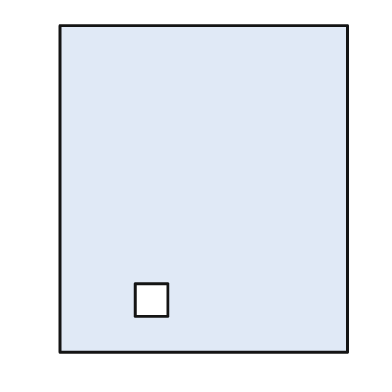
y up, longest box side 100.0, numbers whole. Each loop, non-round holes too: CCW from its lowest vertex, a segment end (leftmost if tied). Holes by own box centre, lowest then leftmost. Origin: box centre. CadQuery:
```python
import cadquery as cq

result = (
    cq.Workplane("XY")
    .moveTo(-44.0, -50.0)
    .lineTo(44.0, -50.0)
    .lineTo(44.0, 50.0)
    .lineTo(-44.0, 50.0)
    .close()
    .moveTo(-21.0, -39.0)
    .lineTo(-11.0, -39.0)
    .lineTo(-11.0, -29.0)
    .lineTo(-21.0, -29.0)
    .close()
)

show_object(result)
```